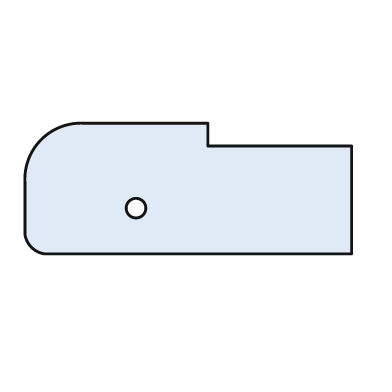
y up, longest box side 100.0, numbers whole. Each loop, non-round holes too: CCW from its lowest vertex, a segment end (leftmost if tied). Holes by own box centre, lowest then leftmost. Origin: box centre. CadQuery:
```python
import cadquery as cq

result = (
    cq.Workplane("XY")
    .moveTo(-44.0, -20.0)
    .lineTo(50.0, -20.0)
    .lineTo(50.0, 13.0)
    .lineTo(6.0, 13.0)
    .lineTo(6.0, 20.0)
    .lineTo(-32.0, 20.0)
    .threePointArc((-45.0, 15.0), (-50.0, 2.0))
    .lineTo(-50.0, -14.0)
    .threePointArc((-48.0, -18.0), (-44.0, -20.0))
    .close()
    .moveTo(-16.0, -6.0)
    .circle(3.0)
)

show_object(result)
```